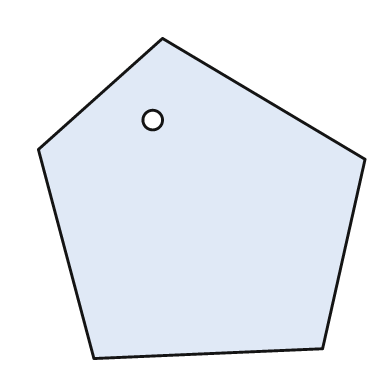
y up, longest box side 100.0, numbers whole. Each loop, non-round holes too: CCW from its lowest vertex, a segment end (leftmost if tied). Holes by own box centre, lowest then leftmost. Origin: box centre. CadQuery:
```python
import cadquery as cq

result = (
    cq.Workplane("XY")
    .moveTo(-33.0, -49.0)
    .lineTo(37.0, -46.0)
    .lineTo(50.0, 12.0)
    .lineTo(-12.0, 49.0)
    .lineTo(-50.0, 15.0)
    .close()
    .moveTo(-15.0, 24.0)
    .circle(3.0)
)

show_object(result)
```